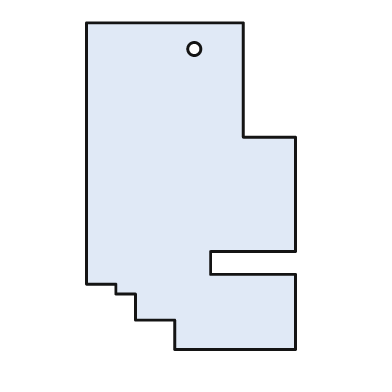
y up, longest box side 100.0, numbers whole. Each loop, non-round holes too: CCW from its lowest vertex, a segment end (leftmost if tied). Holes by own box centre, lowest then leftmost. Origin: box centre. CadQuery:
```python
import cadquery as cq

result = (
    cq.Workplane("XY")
    .moveTo(-5.0, -50.0)
    .lineTo(32.0, -50.0)
    .lineTo(32.0, -27.0)
    .lineTo(6.0, -27.0)
    .lineTo(6.0, -20.0)
    .lineTo(32.0, -20.0)
    .lineTo(32.0, 15.0)
    .lineTo(16.0, 15.0)
    .lineTo(16.0, 50.0)
    .lineTo(-32.0, 50.0)
    .lineTo(-32.0, -30.0)
    .lineTo(-23.0, -30.0)
    .lineTo(-23.0, -33.0)
    .lineTo(-17.0, -33.0)
    .lineTo(-17.0, -41.0)
    .lineTo(-5.0, -41.0)
    .close()
    .moveTo(1.0, 42.0)
    .circle(2.0)
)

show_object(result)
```